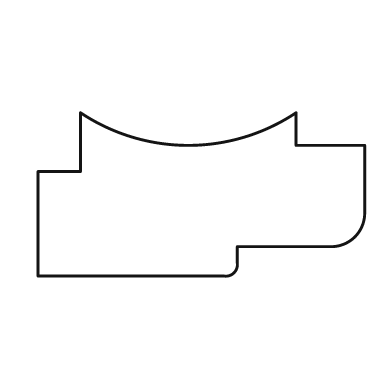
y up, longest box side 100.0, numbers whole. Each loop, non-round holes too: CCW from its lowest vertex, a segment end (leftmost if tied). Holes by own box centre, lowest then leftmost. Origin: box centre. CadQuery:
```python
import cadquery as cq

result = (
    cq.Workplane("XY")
    .moveTo(-50.0, -25.0)
    .lineTo(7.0, -25.0)
    .threePointArc((10.0, -24.0), (11.0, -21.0))
    .lineTo(11.0, -16.0)
    .lineTo(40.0, -16.0)
    .threePointArc((47.0, -13.0), (50.0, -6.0))
    .lineTo(50.0, 15.0)
    .lineTo(29.0, 15.0)
    .lineTo(29.0, 25.0)
    .threePointArc((-4.0, 15.0), (-37.0, 25.0))
    .lineTo(-37.0, 7.0)
    .lineTo(-50.0, 7.0)
    .close()
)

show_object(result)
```